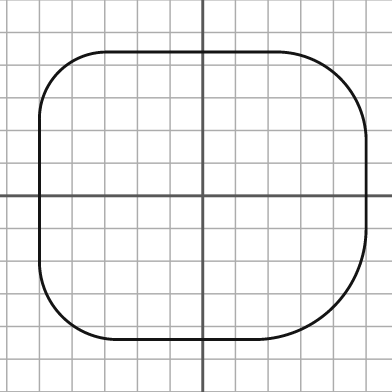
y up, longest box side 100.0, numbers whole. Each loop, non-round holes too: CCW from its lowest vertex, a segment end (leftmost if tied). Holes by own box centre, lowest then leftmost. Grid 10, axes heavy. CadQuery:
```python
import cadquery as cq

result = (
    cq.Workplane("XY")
    .moveTo(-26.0, -44.0)
    .lineTo(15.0, -44.0)
    .threePointArc((40.0, -34.0), (50.0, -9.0))
    .lineTo(50.0, 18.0)
    .threePointArc((42.0, 36.0), (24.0, 44.0))
    .lineTo(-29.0, 44.0)
    .threePointArc((-44.0, 38.0), (-50.0, 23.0))
    .lineTo(-50.0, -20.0)
    .threePointArc((-43.0, -37.0), (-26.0, -44.0))
    .close()
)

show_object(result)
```